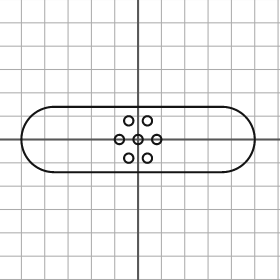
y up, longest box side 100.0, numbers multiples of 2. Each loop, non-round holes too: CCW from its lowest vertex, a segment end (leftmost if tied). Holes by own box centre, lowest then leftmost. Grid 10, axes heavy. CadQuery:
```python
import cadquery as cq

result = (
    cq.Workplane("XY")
    .moveTo(-36.0, -14.0)
    .lineTo(36.0, -14.0)
    .threePointArc((50.0, 0.0), (36.0, 14.0))
    .lineTo(-36.0, 14.0)
    .threePointArc((-50.0, 0.0), (-36.0, -14.0))
    .close()
    .moveTo(-4.0, -8.0)
    .circle(2.0)
    .moveTo(4.0, -8.0)
    .circle(2.0)
    .moveTo(-8.0, 0.0)
    .circle(2.0)
    .moveTo(0.0, 0.0)
    .circle(2.0)
    .moveTo(8.0, 0.0)
    .circle(2.0)
    .moveTo(-4.0, 8.0)
    .circle(2.0)
    .moveTo(4.0, 8.0)
    .circle(2.0)
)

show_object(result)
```